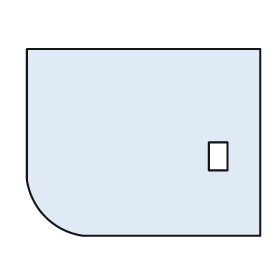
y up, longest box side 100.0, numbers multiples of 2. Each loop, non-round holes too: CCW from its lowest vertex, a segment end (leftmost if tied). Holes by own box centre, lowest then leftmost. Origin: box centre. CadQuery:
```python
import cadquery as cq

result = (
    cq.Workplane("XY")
    .moveTo(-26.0, -40.0)
    .lineTo(50.0, -40.0)
    .lineTo(50.0, 40.0)
    .lineTo(-50.0, 40.0)
    .lineTo(-50.0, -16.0)
    .threePointArc((-42.0, -32.0), (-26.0, -40.0))
    .close()
    .moveTo(28.0, -12.0)
    .lineTo(36.0, -12.0)
    .lineTo(36.0, 0.0)
    .lineTo(28.0, 0.0)
    .close()
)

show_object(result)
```